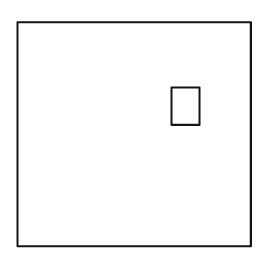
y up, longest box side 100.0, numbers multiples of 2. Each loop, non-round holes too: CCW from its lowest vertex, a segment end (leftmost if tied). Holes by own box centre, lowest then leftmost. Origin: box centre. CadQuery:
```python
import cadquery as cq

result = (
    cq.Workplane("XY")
    .moveTo(-50.0, -48.0)
    .lineTo(50.0, -48.0)
    .lineTo(50.0, 48.0)
    .lineTo(-50.0, 48.0)
    .close()
    .moveTo(16.0, 4.0)
    .lineTo(28.0, 4.0)
    .lineTo(28.0, 20.0)
    .lineTo(16.0, 20.0)
    .close()
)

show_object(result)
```